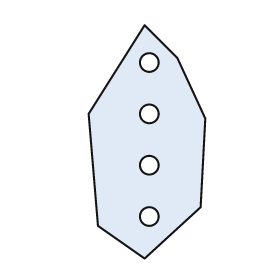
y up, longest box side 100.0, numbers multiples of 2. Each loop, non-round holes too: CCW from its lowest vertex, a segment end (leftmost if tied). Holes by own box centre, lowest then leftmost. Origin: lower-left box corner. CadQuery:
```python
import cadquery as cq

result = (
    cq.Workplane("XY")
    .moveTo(24.0, 0.0)
    .lineTo(48.0, 22.0)
    .lineTo(50.0, 60.0)
    .lineTo(38.0, 86.0)
    .lineTo(24.0, 100.0)
    .lineTo(0.0, 62.0)
    .lineTo(4.0, 14.0)
    .close()
    .moveTo(26.0, 18.0)
    .circle(4.0)
    .moveTo(26.0, 40.0)
    .circle(4.0)
    .moveTo(26.0, 62.0)
    .circle(4.0)
    .moveTo(26.0, 84.0)
    .circle(4.0)
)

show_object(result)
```